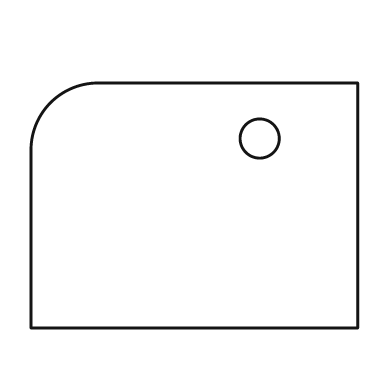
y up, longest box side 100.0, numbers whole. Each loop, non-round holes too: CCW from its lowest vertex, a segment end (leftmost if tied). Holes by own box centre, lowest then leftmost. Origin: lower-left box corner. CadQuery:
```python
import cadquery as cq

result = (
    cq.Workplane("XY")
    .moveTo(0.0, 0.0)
    .lineTo(100.0, 0.0)
    .lineTo(100.0, 75.0)
    .lineTo(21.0, 75.0)
    .threePointArc((6.0, 69.0), (0.0, 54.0))
    .close()
    .moveTo(70.0, 58.0)
    .circle(6.0)
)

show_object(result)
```